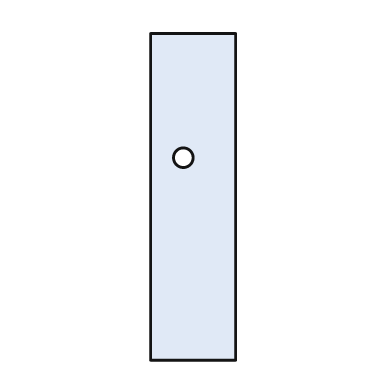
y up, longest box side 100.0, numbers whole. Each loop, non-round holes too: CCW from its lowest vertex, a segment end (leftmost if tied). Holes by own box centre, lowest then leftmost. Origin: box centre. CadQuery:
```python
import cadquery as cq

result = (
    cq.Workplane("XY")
    .moveTo(-13.0, -50.0)
    .lineTo(13.0, -50.0)
    .lineTo(13.0, 50.0)
    .lineTo(-13.0, 50.0)
    .close()
    .moveTo(-3.0, 12.0)
    .circle(3.0)
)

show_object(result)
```